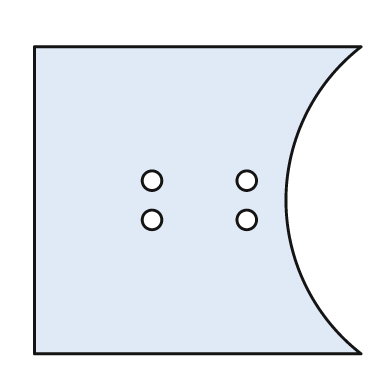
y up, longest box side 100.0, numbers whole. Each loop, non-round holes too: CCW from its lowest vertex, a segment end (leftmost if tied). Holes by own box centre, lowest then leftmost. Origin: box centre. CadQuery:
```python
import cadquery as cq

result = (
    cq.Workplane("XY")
    .moveTo(-50.0, -47.0)
    .lineTo(50.0, -47.0)
    .threePointArc((27.0, 0.0), (50.0, 47.0))
    .lineTo(-50.0, 47.0)
    .close()
    .moveTo(-14.0, -6.0)
    .circle(3.0)
    .moveTo(15.0, -6.0)
    .circle(3.0)
    .moveTo(-14.0, 6.0)
    .circle(3.0)
    .moveTo(15.0, 6.0)
    .circle(3.0)
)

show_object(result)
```